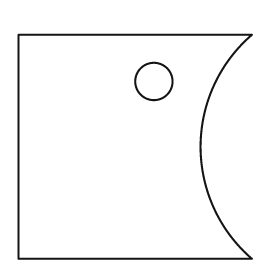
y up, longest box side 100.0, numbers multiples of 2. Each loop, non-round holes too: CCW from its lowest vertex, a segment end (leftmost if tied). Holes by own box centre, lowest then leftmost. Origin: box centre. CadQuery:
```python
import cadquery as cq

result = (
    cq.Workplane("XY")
    .moveTo(-50.0, -48.0)
    .lineTo(50.0, -48.0)
    .threePointArc((28.0, 0.0), (50.0, 48.0))
    .lineTo(-50.0, 48.0)
    .close()
    .moveTo(8.0, 28.0)
    .circle(8.0)
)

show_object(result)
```